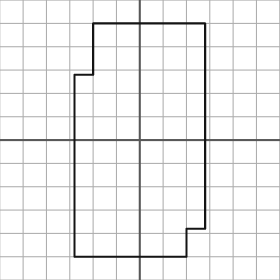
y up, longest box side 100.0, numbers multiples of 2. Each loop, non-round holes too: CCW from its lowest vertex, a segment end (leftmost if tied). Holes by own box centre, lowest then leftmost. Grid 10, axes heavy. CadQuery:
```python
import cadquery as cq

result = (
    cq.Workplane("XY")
    .moveTo(-28.0, -50.0)
    .lineTo(20.0, -50.0)
    .lineTo(20.0, -38.0)
    .lineTo(28.0, -38.0)
    .lineTo(28.0, 50.0)
    .lineTo(-20.0, 50.0)
    .lineTo(-20.0, 28.0)
    .lineTo(-28.0, 28.0)
    .close()
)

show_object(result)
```